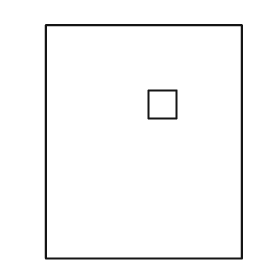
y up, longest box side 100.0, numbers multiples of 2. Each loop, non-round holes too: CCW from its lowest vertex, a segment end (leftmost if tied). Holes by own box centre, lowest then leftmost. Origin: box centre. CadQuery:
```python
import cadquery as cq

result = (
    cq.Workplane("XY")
    .moveTo(-42.0, -50.0)
    .lineTo(42.0, -50.0)
    .lineTo(42.0, 50.0)
    .lineTo(-42.0, 50.0)
    .close()
    .moveTo(2.0, 10.0)
    .lineTo(14.0, 10.0)
    .lineTo(14.0, 22.0)
    .lineTo(2.0, 22.0)
    .close()
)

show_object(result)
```